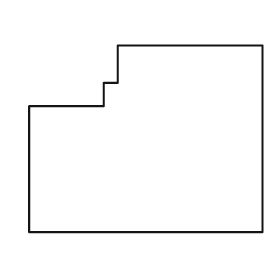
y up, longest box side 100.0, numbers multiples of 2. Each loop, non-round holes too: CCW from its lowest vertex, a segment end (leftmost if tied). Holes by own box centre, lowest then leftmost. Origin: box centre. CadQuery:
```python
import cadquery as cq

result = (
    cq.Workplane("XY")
    .moveTo(-50.0, -40.0)
    .lineTo(50.0, -40.0)
    .lineTo(50.0, 40.0)
    .lineTo(-12.0, 40.0)
    .lineTo(-12.0, 24.0)
    .lineTo(-18.0, 24.0)
    .lineTo(-18.0, 14.0)
    .lineTo(-50.0, 14.0)
    .close()
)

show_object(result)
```